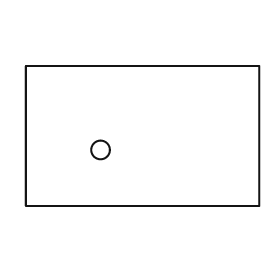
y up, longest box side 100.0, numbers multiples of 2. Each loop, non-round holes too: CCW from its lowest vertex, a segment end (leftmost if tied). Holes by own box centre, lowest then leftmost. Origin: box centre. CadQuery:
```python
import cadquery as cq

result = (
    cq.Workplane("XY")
    .moveTo(-50.0, -30.0)
    .lineTo(50.0, -30.0)
    .lineTo(50.0, 30.0)
    .lineTo(-50.0, 30.0)
    .close()
    .moveTo(-18.0, -6.0)
    .circle(4.0)
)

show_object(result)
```